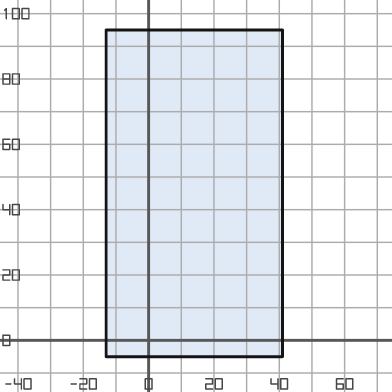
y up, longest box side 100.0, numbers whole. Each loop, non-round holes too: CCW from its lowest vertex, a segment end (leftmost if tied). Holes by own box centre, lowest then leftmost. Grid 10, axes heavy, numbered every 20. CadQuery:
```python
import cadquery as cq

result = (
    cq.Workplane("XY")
    .moveTo(-13.0, -5.0)
    .lineTo(41.0, -5.0)
    .lineTo(41.0, 95.0)
    .lineTo(-13.0, 95.0)
    .close()
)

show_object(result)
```